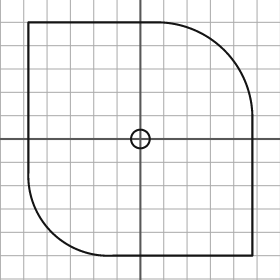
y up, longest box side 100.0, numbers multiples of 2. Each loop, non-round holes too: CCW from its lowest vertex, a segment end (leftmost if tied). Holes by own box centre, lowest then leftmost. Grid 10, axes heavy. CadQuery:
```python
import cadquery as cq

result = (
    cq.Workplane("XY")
    .moveTo(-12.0, -50.0)
    .lineTo(48.0, -50.0)
    .lineTo(48.0, 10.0)
    .threePointArc((36.0, 38.0), (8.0, 50.0))
    .lineTo(-48.0, 50.0)
    .lineTo(-48.0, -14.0)
    .threePointArc((-38.0, -40.0), (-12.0, -50.0))
    .close()
    .moveTo(0.0, 0.0)
    .circle(4.0)
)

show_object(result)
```